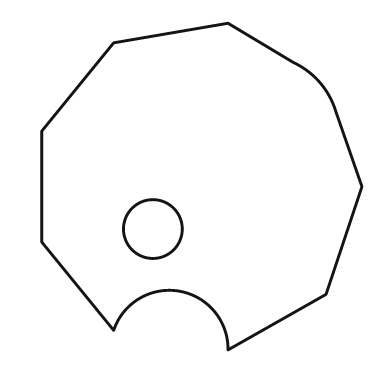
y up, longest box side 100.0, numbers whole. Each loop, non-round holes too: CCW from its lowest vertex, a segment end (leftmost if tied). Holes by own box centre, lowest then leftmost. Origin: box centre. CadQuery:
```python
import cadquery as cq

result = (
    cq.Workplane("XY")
    .moveTo(8.0, -50.0)
    .lineTo(38.0, -33.0)
    .lineTo(49.0, 0.0)
    .lineTo(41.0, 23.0)
    .threePointArc((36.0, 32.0), (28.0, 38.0))
    .lineTo(8.0, 50.0)
    .lineTo(-27.0, 44.0)
    .lineTo(-49.0, 17.0)
    .lineTo(-49.0, -17.0)
    .lineTo(-27.0, -44.0)
    .threePointArc((-7.0, -32.0), (8.0, -50.0))
    .close()
    .moveTo(-15.0, -13.0)
    .circle(9.0)
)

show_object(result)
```